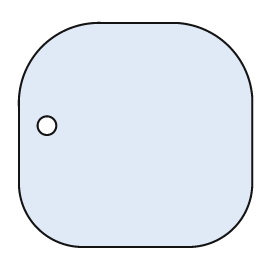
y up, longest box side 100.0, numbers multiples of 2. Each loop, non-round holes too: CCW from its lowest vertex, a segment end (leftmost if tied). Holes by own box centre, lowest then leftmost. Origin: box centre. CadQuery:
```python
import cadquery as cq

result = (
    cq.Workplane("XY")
    .moveTo(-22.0, -48.0)
    .lineTo(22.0, -48.0)
    .threePointArc((42.0, -40.0), (50.0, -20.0))
    .lineTo(50.0, 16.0)
    .threePointArc((40.0, 38.0), (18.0, 48.0))
    .lineTo(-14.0, 48.0)
    .threePointArc((-40.0, 38.0), (-50.0, 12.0))
    .lineTo(-50.0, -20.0)
    .threePointArc((-42.0, -40.0), (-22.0, -48.0))
    .close()
    .moveTo(-38.0, 4.0)
    .circle(4.0)
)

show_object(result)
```